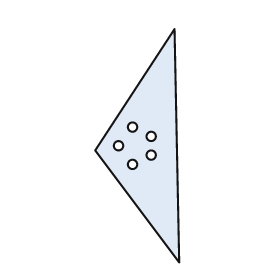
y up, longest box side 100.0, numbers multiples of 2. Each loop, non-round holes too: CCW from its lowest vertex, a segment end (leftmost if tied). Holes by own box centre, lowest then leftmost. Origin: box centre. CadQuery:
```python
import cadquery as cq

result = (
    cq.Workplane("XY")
    .moveTo(18.0, -50.0)
    .lineTo(16.0, 50.0)
    .lineTo(-18.0, -2.0)
    .close()
    .moveTo(-2.0, -8.0)
    .circle(2.0)
    .moveTo(6.0, -4.0)
    .circle(2.0)
    .moveTo(-8.0, 0.0)
    .circle(2.0)
    .moveTo(6.0, 4.0)
    .circle(2.0)
    .moveTo(-2.0, 8.0)
    .circle(2.0)
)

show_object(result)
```